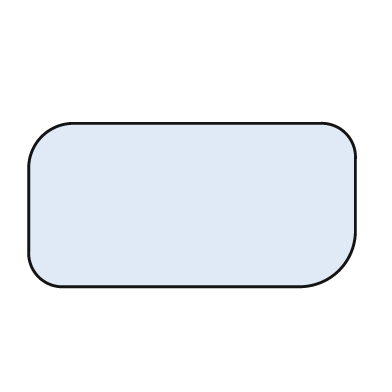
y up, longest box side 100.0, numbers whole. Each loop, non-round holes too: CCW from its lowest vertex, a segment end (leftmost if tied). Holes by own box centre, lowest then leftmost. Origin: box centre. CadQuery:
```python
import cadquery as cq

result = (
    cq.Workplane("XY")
    .moveTo(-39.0, -25.0)
    .lineTo(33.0, -25.0)
    .threePointArc((45.0, -20.0), (50.0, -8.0))
    .lineTo(50.0, 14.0)
    .threePointArc((47.0, 22.0), (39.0, 25.0))
    .lineTo(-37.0, 25.0)
    .threePointArc((-46.0, 21.0), (-50.0, 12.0))
    .lineTo(-50.0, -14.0)
    .threePointArc((-47.0, -22.0), (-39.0, -25.0))
    .close()
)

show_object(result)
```